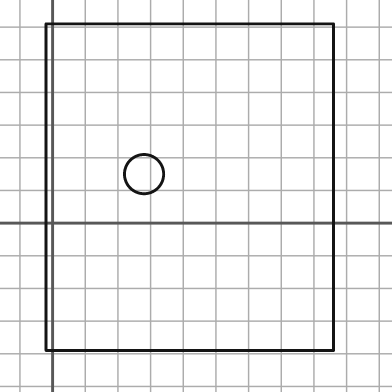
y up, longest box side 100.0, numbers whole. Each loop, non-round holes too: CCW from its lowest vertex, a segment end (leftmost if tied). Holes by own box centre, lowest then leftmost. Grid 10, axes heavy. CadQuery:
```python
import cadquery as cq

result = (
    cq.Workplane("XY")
    .moveTo(-2.0, -39.0)
    .lineTo(86.0, -39.0)
    .lineTo(86.0, 61.0)
    .lineTo(-2.0, 61.0)
    .close()
    .moveTo(28.0, 15.0)
    .circle(6.0)
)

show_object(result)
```